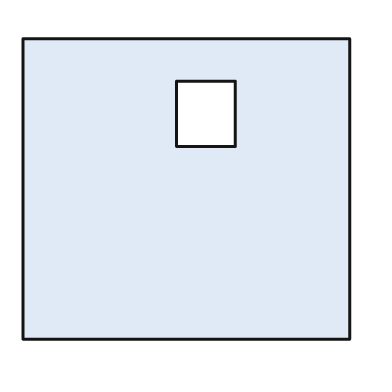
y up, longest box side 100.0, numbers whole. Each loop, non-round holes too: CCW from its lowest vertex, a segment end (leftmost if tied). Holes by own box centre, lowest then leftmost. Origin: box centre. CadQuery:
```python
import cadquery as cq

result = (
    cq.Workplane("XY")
    .moveTo(-50.0, -46.0)
    .lineTo(50.0, -46.0)
    .lineTo(50.0, 46.0)
    .lineTo(-50.0, 46.0)
    .close()
    .moveTo(-3.0, 13.0)
    .lineTo(15.0, 13.0)
    .lineTo(15.0, 33.0)
    .lineTo(-3.0, 33.0)
    .close()
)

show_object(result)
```